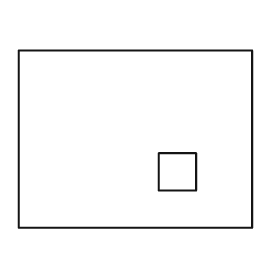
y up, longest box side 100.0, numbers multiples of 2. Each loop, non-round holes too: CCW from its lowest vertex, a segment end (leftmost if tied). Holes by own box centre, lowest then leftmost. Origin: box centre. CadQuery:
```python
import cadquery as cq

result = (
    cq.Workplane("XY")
    .moveTo(-50.0, -38.0)
    .lineTo(50.0, -38.0)
    .lineTo(50.0, 38.0)
    .lineTo(-50.0, 38.0)
    .close()
    .moveTo(10.0, -22.0)
    .lineTo(26.0, -22.0)
    .lineTo(26.0, -6.0)
    .lineTo(10.0, -6.0)
    .close()
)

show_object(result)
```